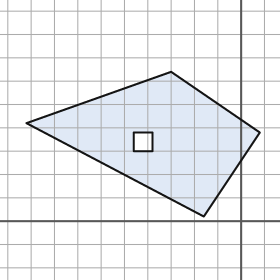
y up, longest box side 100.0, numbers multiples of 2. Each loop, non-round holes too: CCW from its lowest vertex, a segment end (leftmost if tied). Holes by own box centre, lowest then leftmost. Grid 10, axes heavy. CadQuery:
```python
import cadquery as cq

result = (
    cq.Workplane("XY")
    .moveTo(-16.0, 2.0)
    .lineTo(8.0, 38.0)
    .lineTo(-30.0, 64.0)
    .lineTo(-92.0, 42.0)
    .close()
    .moveTo(-46.0, 30.0)
    .lineTo(-38.0, 30.0)
    .lineTo(-38.0, 38.0)
    .lineTo(-46.0, 38.0)
    .close()
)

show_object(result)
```